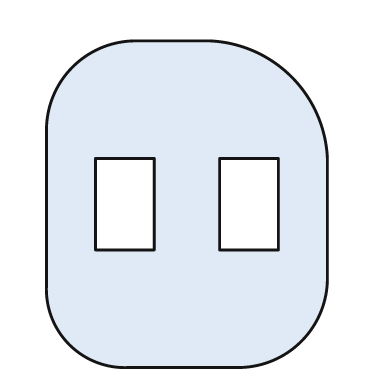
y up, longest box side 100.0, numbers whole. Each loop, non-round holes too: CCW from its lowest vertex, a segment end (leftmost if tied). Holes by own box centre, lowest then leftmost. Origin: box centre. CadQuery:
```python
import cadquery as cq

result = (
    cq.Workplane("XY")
    .moveTo(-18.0, -50.0)
    .lineTo(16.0, -50.0)
    .threePointArc((35.0, -42.0), (43.0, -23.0))
    .lineTo(43.0, 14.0)
    .threePointArc((32.0, 39.0), (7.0, 50.0))
    .lineTo(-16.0, 50.0)
    .threePointArc((-35.0, 42.0), (-43.0, 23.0))
    .lineTo(-43.0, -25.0)
    .threePointArc((-36.0, -43.0), (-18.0, -50.0))
    .close()
    .moveTo(-28.0, -14.0)
    .lineTo(-10.0, -14.0)
    .lineTo(-10.0, 14.0)
    .lineTo(-28.0, 14.0)
    .close()
    .moveTo(10.0, -14.0)
    .lineTo(28.0, -14.0)
    .lineTo(28.0, 14.0)
    .lineTo(10.0, 14.0)
    .close()
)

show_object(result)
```